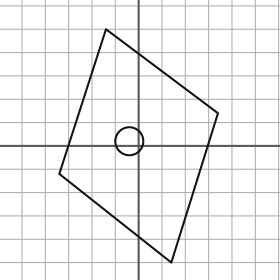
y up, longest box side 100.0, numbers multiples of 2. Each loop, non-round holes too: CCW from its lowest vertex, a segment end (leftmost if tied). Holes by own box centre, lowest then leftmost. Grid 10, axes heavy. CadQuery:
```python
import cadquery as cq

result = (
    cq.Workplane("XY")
    .moveTo(14.0, -50.0)
    .lineTo(34.0, 14.0)
    .lineTo(-14.0, 50.0)
    .lineTo(-34.0, -12.0)
    .close()
    .moveTo(-4.0, 2.0)
    .circle(6.0)
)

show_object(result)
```